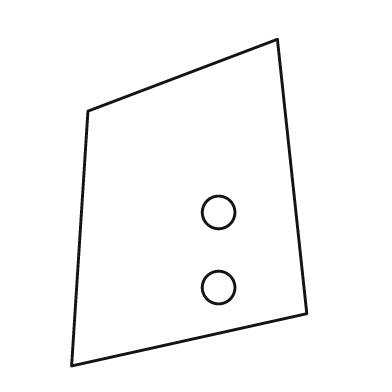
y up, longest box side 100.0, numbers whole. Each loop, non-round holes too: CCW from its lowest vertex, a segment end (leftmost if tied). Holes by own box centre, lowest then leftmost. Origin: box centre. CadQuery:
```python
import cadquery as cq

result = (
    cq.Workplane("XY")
    .moveTo(-36.0, -50.0)
    .lineTo(36.0, -34.0)
    .lineTo(27.0, 50.0)
    .lineTo(-31.0, 28.0)
    .close()
    .moveTo(9.0, -26.0)
    .circle(5.0)
    .moveTo(9.0, -3.0)
    .circle(5.0)
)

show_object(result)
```